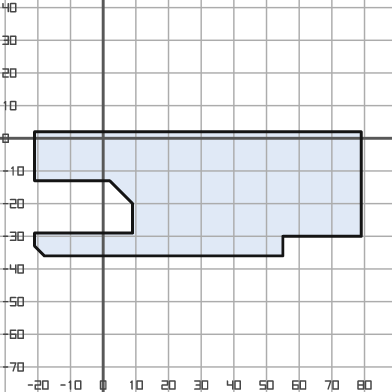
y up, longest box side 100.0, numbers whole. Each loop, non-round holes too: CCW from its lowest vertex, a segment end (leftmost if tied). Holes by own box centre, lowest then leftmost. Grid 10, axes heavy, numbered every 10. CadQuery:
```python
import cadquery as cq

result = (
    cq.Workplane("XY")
    .moveTo(-18.0, -36.0)
    .lineTo(55.0, -36.0)
    .lineTo(55.0, -30.0)
    .lineTo(79.0, -30.0)
    .lineTo(79.0, 2.0)
    .lineTo(-21.0, 2.0)
    .lineTo(-21.0, -13.0)
    .lineTo(2.0, -13.0)
    .lineTo(9.0, -20.0)
    .lineTo(9.0, -29.0)
    .lineTo(-21.0, -29.0)
    .lineTo(-21.0, -33.0)
    .close()
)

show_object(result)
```